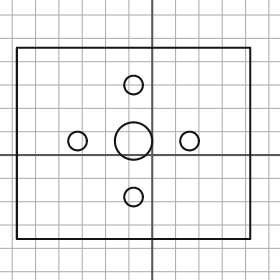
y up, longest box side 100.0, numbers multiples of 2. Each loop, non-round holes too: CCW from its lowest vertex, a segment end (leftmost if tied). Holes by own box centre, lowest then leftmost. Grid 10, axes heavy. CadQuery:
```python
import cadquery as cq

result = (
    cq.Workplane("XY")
    .moveTo(-58.0, -36.0)
    .lineTo(42.0, -36.0)
    .lineTo(42.0, 46.0)
    .lineTo(-58.0, 46.0)
    .close()
    .moveTo(-8.0, -18.0)
    .circle(4.0)
    .moveTo(-32.0, 6.0)
    .circle(4.0)
    .moveTo(-8.0, 6.0)
    .circle(8.0)
    .moveTo(16.0, 6.0)
    .circle(4.0)
    .moveTo(-8.0, 30.0)
    .circle(4.0)
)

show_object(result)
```